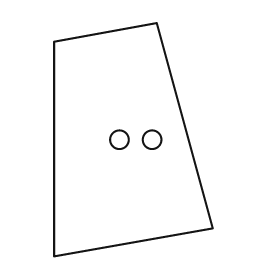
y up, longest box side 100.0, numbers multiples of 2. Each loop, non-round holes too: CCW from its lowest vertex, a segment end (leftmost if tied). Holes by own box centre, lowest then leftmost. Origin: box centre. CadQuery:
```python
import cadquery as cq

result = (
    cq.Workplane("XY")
    .moveTo(-34.0, -50.0)
    .lineTo(34.0, -38.0)
    .lineTo(10.0, 50.0)
    .lineTo(-34.0, 42.0)
    .close()
    .moveTo(-6.0, 0.0)
    .circle(4.0)
    .moveTo(8.0, 0.0)
    .circle(4.0)
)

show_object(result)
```